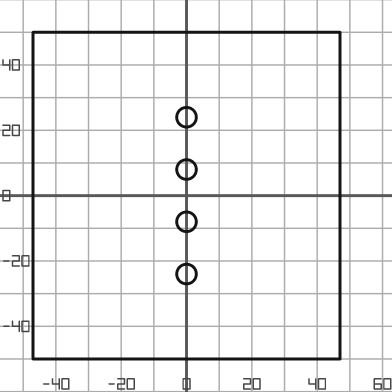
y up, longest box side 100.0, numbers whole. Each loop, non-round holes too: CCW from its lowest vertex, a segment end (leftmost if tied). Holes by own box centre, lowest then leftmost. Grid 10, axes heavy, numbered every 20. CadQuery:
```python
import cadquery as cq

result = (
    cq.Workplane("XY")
    .moveTo(-47.0, -50.0)
    .lineTo(47.0, -50.0)
    .lineTo(47.0, 50.0)
    .lineTo(-47.0, 50.0)
    .close()
    .moveTo(0.0, -24.0)
    .circle(3.0)
    .moveTo(0.0, -8.0)
    .circle(3.0)
    .moveTo(0.0, 8.0)
    .circle(3.0)
    .moveTo(0.0, 24.0)
    .circle(3.0)
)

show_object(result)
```